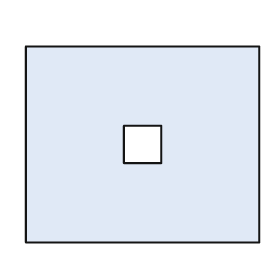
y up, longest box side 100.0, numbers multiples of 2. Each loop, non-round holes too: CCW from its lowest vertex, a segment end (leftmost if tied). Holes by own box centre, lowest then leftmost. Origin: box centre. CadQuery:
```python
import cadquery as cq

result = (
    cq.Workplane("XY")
    .moveTo(-50.0, -42.0)
    .lineTo(50.0, -42.0)
    .lineTo(50.0, 42.0)
    .lineTo(-50.0, 42.0)
    .close()
    .moveTo(-8.0, -8.0)
    .lineTo(8.0, -8.0)
    .lineTo(8.0, 8.0)
    .lineTo(-8.0, 8.0)
    .close()
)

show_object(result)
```